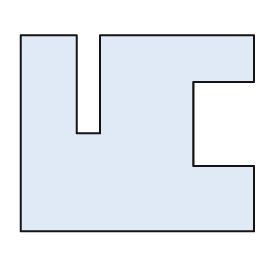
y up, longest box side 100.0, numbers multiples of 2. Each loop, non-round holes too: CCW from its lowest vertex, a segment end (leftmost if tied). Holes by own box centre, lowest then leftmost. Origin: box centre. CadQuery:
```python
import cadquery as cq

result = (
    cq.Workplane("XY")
    .moveTo(-50.0, -42.0)
    .lineTo(50.0, -42.0)
    .lineTo(50.0, -14.0)
    .lineTo(24.0, -14.0)
    .lineTo(24.0, 22.0)
    .lineTo(50.0, 22.0)
    .lineTo(50.0, 42.0)
    .lineTo(-16.0, 42.0)
    .lineTo(-16.0, 0.0)
    .lineTo(-26.0, 0.0)
    .lineTo(-26.0, 42.0)
    .lineTo(-50.0, 42.0)
    .close()
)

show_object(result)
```